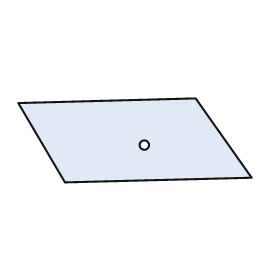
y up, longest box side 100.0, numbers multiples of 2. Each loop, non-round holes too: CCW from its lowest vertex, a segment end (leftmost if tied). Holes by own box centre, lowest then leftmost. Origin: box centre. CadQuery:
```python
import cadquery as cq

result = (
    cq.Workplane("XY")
    .moveTo(-30.0, -18.0)
    .lineTo(50.0, -16.0)
    .lineTo(26.0, 18.0)
    .lineTo(-50.0, 16.0)
    .close()
    .moveTo(4.0, -2.0)
    .circle(2.0)
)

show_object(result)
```